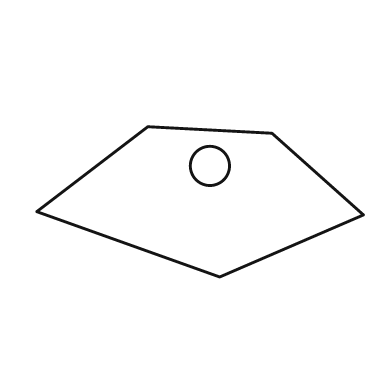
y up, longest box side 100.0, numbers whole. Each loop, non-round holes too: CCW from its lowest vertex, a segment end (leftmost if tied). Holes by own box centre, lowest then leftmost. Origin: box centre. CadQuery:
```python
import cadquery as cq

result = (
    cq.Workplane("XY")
    .moveTo(6.0, -23.0)
    .lineTo(50.0, -4.0)
    .lineTo(22.0, 21.0)
    .lineTo(-16.0, 23.0)
    .lineTo(-50.0, -3.0)
    .close()
    .moveTo(3.0, 11.0)
    .circle(6.0)
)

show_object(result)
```